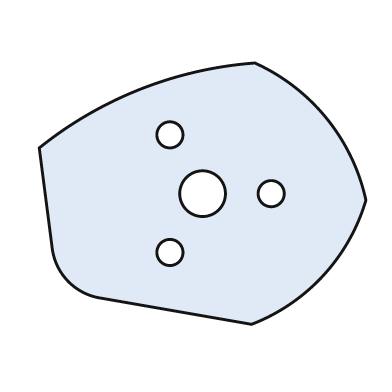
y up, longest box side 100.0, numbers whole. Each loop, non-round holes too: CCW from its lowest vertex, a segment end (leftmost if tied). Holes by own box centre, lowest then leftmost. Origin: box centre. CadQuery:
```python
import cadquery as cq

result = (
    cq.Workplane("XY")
    .moveTo(15.0, -40.0)
    .threePointArc((37.0, -25.0), (50.0, -2.0))
    .threePointArc((38.0, 23.0), (16.0, 40.0))
    .threePointArc((-19.0, 32.0), (-50.0, 14.0))
    .lineTo(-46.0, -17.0)
    .threePointArc((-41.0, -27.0), (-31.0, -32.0))
    .close()
    .moveTo(-10.0, -18.0)
    .circle(4.0)
    .moveTo(0.0, 0.0)
    .circle(7.0)
    .moveTo(21.0, 0.0)
    .circle(4.0)
    .moveTo(-10.0, 18.0)
    .circle(4.0)
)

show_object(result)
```